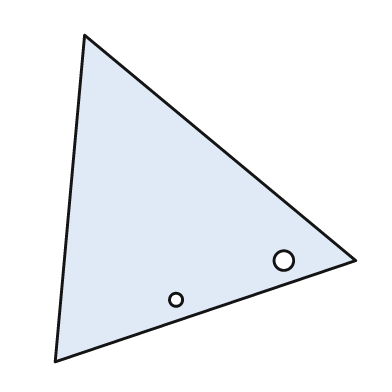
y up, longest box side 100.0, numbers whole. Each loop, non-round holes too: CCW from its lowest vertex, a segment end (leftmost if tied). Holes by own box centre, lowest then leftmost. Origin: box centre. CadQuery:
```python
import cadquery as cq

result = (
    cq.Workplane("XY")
    .moveTo(-46.0, -50.0)
    .lineTo(46.0, -19.0)
    .lineTo(-37.0, 50.0)
    .close()
    .moveTo(-9.0, -31.0)
    .circle(2.0)
    .moveTo(24.0, -19.0)
    .circle(3.0)
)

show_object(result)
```